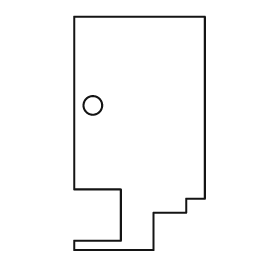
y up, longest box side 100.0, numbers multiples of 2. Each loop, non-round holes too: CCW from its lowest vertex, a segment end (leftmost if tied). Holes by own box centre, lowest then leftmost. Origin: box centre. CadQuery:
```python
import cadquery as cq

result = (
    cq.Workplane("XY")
    .moveTo(-28.0, -50.0)
    .lineTo(6.0, -50.0)
    .lineTo(6.0, -34.0)
    .lineTo(20.0, -34.0)
    .lineTo(20.0, -28.0)
    .lineTo(28.0, -28.0)
    .lineTo(28.0, 50.0)
    .lineTo(-28.0, 50.0)
    .lineTo(-28.0, -24.0)
    .lineTo(-8.0, -24.0)
    .lineTo(-8.0, -46.0)
    .lineTo(-28.0, -46.0)
    .close()
    .moveTo(-20.0, 12.0)
    .circle(4.0)
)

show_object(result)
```